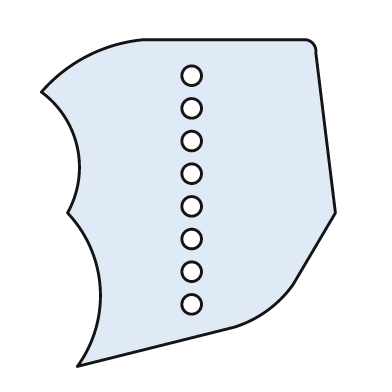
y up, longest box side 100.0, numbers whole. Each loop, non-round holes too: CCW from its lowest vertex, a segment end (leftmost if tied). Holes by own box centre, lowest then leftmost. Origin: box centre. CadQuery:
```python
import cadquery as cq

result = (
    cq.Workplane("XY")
    .moveTo(-34.0, -50.0)
    .lineTo(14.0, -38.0)
    .threePointArc((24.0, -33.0), (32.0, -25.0))
    .lineTo(45.0, -3.0)
    .lineTo(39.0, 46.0)
    .threePointArc((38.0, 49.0), (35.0, 50.0))
    .lineTo(-14.0, 50.0)
    .threePointArc((-31.0, 45.0), (-45.0, 34.0))
    .threePointArc((-34.0, 17.0), (-37.0, -3.0))
    .threePointArc((-27.0, -26.0), (-34.0, -50.0))
    .close()
    .moveTo(1.0, -31.0)
    .circle(3.0)
    .moveTo(1.0, -21.0)
    .circle(3.0)
    .moveTo(1.0, -11.0)
    .circle(3.0)
    .moveTo(1.0, -1.0)
    .circle(3.0)
    .moveTo(1.0, 9.0)
    .circle(3.0)
    .moveTo(1.0, 19.0)
    .circle(3.0)
    .moveTo(1.0, 29.0)
    .circle(3.0)
    .moveTo(1.0, 39.0)
    .circle(3.0)
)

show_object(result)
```